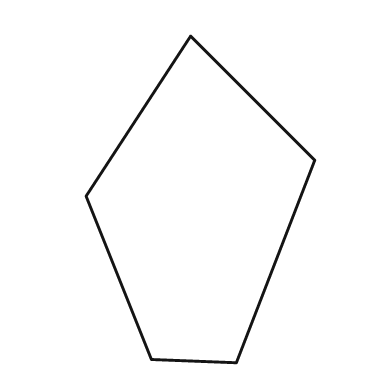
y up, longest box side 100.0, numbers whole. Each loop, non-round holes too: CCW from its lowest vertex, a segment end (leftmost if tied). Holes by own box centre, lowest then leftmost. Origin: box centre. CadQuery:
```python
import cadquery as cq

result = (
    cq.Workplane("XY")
    .moveTo(11.0, -50.0)
    .lineTo(35.0, 12.0)
    .lineTo(-3.0, 50.0)
    .lineTo(-35.0, 1.0)
    .lineTo(-15.0, -49.0)
    .close()
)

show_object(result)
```